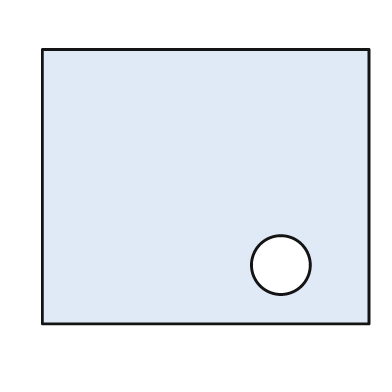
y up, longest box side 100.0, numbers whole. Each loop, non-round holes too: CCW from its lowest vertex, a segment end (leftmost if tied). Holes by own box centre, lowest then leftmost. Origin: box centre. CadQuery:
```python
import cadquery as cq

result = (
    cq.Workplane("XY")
    .moveTo(-50.0, -42.0)
    .lineTo(50.0, -42.0)
    .lineTo(50.0, 42.0)
    .lineTo(-50.0, 42.0)
    .close()
    .moveTo(23.0, -24.0)
    .circle(9.0)
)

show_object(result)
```